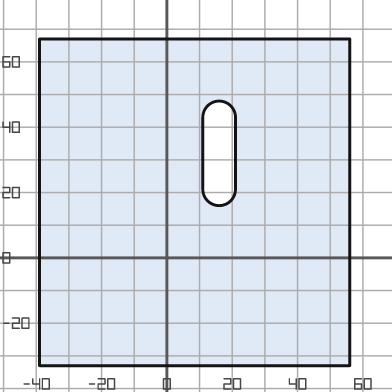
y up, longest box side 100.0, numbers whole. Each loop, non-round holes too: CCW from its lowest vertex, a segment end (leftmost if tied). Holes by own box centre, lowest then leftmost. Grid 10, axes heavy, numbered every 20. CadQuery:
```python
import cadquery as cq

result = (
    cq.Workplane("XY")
    .moveTo(-39.0, -33.0)
    .lineTo(56.0, -33.0)
    .lineTo(56.0, 67.0)
    .lineTo(-39.0, 67.0)
    .close()
    .moveTo(11.0, 21.0)
    .threePointArc((16.0, 16.0), (21.0, 21.0))
    .lineTo(21.0, 43.0)
    .threePointArc((16.0, 48.0), (11.0, 43.0))
    .close()
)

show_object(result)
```